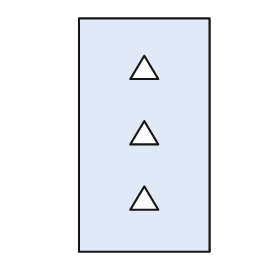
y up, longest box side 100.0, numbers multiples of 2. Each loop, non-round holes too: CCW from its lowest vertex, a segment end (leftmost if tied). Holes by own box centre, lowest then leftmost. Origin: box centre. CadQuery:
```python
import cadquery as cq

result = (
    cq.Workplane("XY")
    .moveTo(-28.0, -50.0)
    .lineTo(28.0, -50.0)
    .lineTo(28.0, 50.0)
    .lineTo(-28.0, 50.0)
    .close()
    .moveTo(-6.0, -32.0)
    .lineTo(6.0, -32.0)
    .lineTo(0.0, -22.0)
    .close()
    .moveTo(-6.0, -4.0)
    .lineTo(6.0, -4.0)
    .lineTo(0.0, 6.0)
    .close()
    .moveTo(-6.0, 24.0)
    .lineTo(6.0, 24.0)
    .lineTo(0.0, 34.0)
    .close()
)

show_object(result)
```